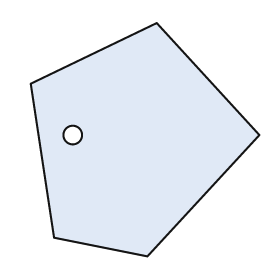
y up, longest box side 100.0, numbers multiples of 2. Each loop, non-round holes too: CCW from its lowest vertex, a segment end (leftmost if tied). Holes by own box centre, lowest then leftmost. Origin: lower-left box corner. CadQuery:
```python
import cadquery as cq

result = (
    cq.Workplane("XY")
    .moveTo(50.0, 0.0)
    .lineTo(98.0, 52.0)
    .lineTo(54.0, 100.0)
    .lineTo(0.0, 74.0)
    .lineTo(10.0, 8.0)
    .close()
    .moveTo(18.0, 52.0)
    .circle(4.0)
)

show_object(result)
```